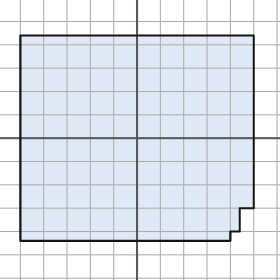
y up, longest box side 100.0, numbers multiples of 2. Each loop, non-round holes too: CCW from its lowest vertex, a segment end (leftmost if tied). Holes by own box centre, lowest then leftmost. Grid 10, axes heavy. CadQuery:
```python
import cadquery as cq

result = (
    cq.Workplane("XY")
    .moveTo(-50.0, -44.0)
    .lineTo(40.0, -44.0)
    .lineTo(40.0, -40.0)
    .lineTo(44.0, -40.0)
    .lineTo(44.0, -30.0)
    .lineTo(50.0, -30.0)
    .lineTo(50.0, 44.0)
    .lineTo(-50.0, 44.0)
    .close()
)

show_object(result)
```